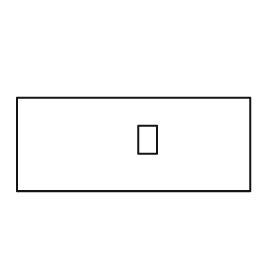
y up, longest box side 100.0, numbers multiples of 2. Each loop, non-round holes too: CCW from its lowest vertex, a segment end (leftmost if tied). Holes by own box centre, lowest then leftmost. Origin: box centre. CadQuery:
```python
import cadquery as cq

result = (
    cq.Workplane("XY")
    .moveTo(-50.0, -20.0)
    .lineTo(50.0, -20.0)
    .lineTo(50.0, 20.0)
    .lineTo(-50.0, 20.0)
    .close()
    .moveTo(2.0, -4.0)
    .lineTo(10.0, -4.0)
    .lineTo(10.0, 8.0)
    .lineTo(2.0, 8.0)
    .close()
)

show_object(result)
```